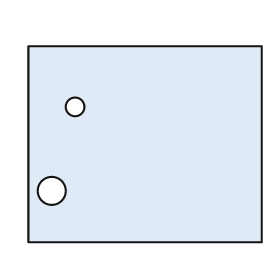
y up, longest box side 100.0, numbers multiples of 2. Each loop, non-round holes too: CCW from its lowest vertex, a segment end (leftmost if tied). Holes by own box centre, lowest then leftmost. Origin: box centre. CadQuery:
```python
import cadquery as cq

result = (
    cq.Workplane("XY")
    .moveTo(-50.0, -42.0)
    .lineTo(50.0, -42.0)
    .lineTo(50.0, 42.0)
    .lineTo(-50.0, 42.0)
    .close()
    .moveTo(-40.0, -20.0)
    .circle(6.0)
    .moveTo(-30.0, 16.0)
    .circle(4.0)
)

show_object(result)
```